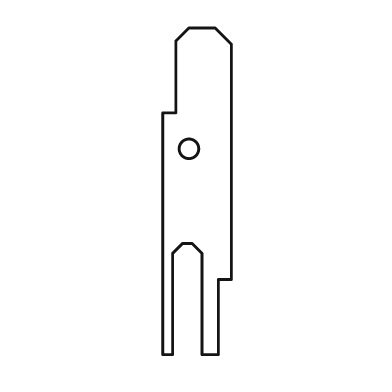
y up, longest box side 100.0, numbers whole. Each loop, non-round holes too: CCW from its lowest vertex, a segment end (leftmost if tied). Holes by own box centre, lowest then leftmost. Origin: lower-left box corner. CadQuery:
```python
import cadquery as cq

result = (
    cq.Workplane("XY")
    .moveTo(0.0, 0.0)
    .lineTo(3.0, 0.0)
    .lineTo(3.0, 31.0)
    .lineTo(6.0, 34.0)
    .lineTo(9.0, 34.0)
    .lineTo(12.0, 31.0)
    .lineTo(12.0, 0.0)
    .lineTo(17.0, 0.0)
    .lineTo(17.0, 23.0)
    .lineTo(21.0, 23.0)
    .lineTo(21.0, 95.0)
    .lineTo(16.0, 100.0)
    .lineTo(8.0, 100.0)
    .lineTo(4.0, 96.0)
    .lineTo(4.0, 74.0)
    .lineTo(0.0, 74.0)
    .close()
    .moveTo(8.0, 63.0)
    .circle(3.0)
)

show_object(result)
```